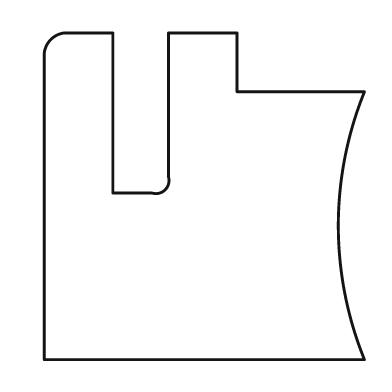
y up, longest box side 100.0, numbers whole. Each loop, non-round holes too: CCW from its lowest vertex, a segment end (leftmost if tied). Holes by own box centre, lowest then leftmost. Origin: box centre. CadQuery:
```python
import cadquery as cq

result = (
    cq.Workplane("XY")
    .moveTo(-49.0, -50.0)
    .lineTo(49.0, -50.0)
    .threePointArc((41.0, -9.0), (49.0, 32.0))
    .lineTo(10.0, 32.0)
    .lineTo(10.0, 50.0)
    .lineTo(-11.0, 50.0)
    .lineTo(-11.0, 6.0)
    .threePointArc((-12.0, 2.0), (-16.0, 1.0))
    .lineTo(-28.0, 1.0)
    .lineTo(-28.0, 50.0)
    .lineTo(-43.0, 50.0)
    .threePointArc((-47.0, 48.0), (-49.0, 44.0))
    .close()
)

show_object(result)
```